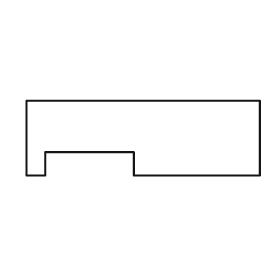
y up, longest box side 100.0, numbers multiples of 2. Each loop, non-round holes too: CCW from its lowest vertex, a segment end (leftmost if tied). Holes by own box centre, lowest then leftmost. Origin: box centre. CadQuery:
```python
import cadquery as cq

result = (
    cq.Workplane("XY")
    .moveTo(-50.0, -16.0)
    .lineTo(-42.0, -16.0)
    .lineTo(-42.0, -6.0)
    .lineTo(-4.0, -6.0)
    .lineTo(-4.0, -16.0)
    .lineTo(50.0, -16.0)
    .lineTo(50.0, 16.0)
    .lineTo(-50.0, 16.0)
    .close()
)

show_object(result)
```